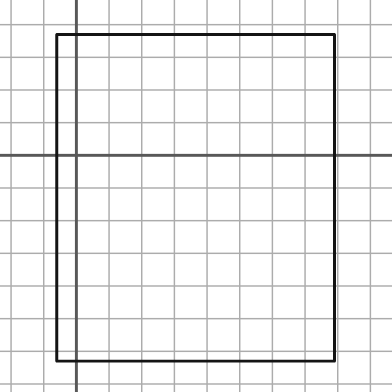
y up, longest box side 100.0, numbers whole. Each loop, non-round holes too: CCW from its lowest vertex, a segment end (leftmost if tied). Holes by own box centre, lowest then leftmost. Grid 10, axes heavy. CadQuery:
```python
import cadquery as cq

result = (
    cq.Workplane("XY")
    .moveTo(-6.0, -63.0)
    .lineTo(79.0, -63.0)
    .lineTo(79.0, 37.0)
    .lineTo(-6.0, 37.0)
    .close()
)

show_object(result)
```